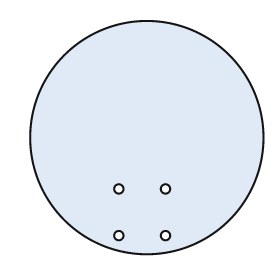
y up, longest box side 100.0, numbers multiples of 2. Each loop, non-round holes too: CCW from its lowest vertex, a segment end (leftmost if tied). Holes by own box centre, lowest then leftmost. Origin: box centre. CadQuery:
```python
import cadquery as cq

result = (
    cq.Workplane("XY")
    .moveTo(0.0, 0.0)
    .circle(50.0)
    .moveTo(-12.0, -42.0)
    .circle(2.0)
    .moveTo(8.0, -42.0)
    .circle(2.0)
    .moveTo(-12.0, -22.0)
    .circle(2.0)
    .moveTo(8.0, -22.0)
    .circle(2.0)
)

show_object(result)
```